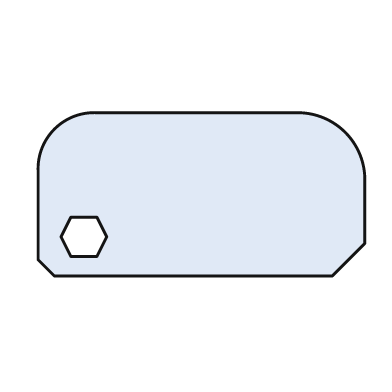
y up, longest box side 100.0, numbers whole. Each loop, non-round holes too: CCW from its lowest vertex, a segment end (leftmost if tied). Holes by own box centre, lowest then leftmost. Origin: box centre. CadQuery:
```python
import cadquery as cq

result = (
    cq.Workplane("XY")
    .moveTo(-45.0, -25.0)
    .lineTo(40.0, -25.0)
    .lineTo(50.0, -15.0)
    .lineTo(50.0, 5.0)
    .threePointArc((44.0, 19.0), (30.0, 25.0))
    .lineTo(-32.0, 25.0)
    .threePointArc((-45.0, 20.0), (-50.0, 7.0))
    .lineTo(-50.0, -20.0)
    .close()
    .moveTo(-40.0, -19.0)
    .lineTo(-32.0, -19.0)
    .lineTo(-29.0, -13.0)
    .lineTo(-32.0, -7.0)
    .lineTo(-40.0, -7.0)
    .lineTo(-43.0, -13.0)
    .close()
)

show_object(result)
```